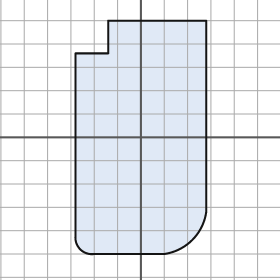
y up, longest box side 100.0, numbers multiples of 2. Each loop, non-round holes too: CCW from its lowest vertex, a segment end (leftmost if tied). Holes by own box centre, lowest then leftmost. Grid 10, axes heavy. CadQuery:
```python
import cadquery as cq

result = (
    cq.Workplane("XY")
    .moveTo(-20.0, -50.0)
    .lineTo(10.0, -50.0)
    .threePointArc((22.0, -44.0), (28.0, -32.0))
    .lineTo(28.0, 50.0)
    .lineTo(-14.0, 50.0)
    .lineTo(-14.0, 36.0)
    .lineTo(-28.0, 36.0)
    .lineTo(-28.0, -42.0)
    .threePointArc((-26.0, -48.0), (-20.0, -50.0))
    .close()
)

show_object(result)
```